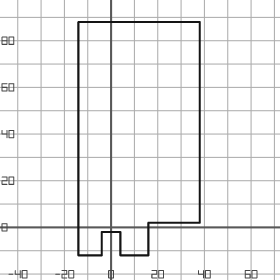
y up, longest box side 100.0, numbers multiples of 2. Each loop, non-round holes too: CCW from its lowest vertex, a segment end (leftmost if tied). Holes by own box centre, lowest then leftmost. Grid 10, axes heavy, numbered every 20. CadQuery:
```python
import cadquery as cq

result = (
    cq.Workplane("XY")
    .moveTo(-14.0, -12.0)
    .lineTo(-4.0, -12.0)
    .lineTo(-4.0, -2.0)
    .lineTo(4.0, -2.0)
    .lineTo(4.0, -12.0)
    .lineTo(16.0, -12.0)
    .lineTo(16.0, 2.0)
    .lineTo(38.0, 2.0)
    .lineTo(38.0, 88.0)
    .lineTo(-14.0, 88.0)
    .close()
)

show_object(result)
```